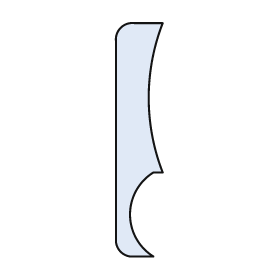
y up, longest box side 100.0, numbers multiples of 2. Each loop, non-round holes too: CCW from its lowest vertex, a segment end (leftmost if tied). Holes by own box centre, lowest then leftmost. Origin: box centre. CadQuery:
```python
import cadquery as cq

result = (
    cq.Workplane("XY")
    .moveTo(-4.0, -50.0)
    .lineTo(6.0, -50.0)
    .threePointArc((-4.0, -32.0), (6.0, -14.0))
    .lineTo(10.0, -14.0)
    .threePointArc((4.0, 18.0), (10.0, 50.0))
    .lineTo(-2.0, 50.0)
    .threePointArc((-8.0, 48.0), (-10.0, 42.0))
    .lineTo(-10.0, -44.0)
    .threePointArc((-8.0, -48.0), (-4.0, -50.0))
    .close()
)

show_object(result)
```